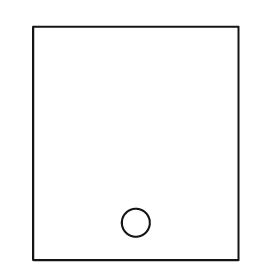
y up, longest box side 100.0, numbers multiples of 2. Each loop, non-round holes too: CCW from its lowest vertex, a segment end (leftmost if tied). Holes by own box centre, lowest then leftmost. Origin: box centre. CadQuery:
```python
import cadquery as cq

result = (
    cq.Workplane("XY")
    .moveTo(-44.0, -50.0)
    .lineTo(44.0, -50.0)
    .lineTo(44.0, 50.0)
    .lineTo(-44.0, 50.0)
    .close()
    .moveTo(0.0, -34.0)
    .circle(6.0)
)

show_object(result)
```